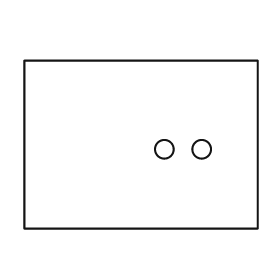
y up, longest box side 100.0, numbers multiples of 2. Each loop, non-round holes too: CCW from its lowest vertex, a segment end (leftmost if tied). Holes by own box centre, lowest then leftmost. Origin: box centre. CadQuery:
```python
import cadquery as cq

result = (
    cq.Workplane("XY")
    .moveTo(-50.0, -36.0)
    .lineTo(50.0, -36.0)
    .lineTo(50.0, 36.0)
    .lineTo(-50.0, 36.0)
    .close()
    .moveTo(10.0, -2.0)
    .circle(4.0)
    .moveTo(26.0, -2.0)
    .circle(4.0)
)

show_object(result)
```